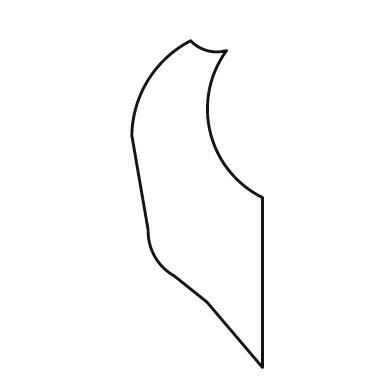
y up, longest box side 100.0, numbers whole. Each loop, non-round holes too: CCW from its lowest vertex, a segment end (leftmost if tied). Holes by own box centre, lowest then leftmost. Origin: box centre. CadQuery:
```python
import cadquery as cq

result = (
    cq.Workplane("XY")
    .moveTo(20.0, -50.0)
    .lineTo(20.0, 2.0)
    .threePointArc((4.0, 22.0), (9.0, 47.0))
    .threePointArc((3.0, 47.0), (-2.0, 50.0))
    .threePointArc((-15.0, 38.0), (-20.0, 21.0))
    .lineTo(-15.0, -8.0)
    .threePointArc((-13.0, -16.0), (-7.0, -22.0))
    .lineTo(3.0, -30.0)
    .close()
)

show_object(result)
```